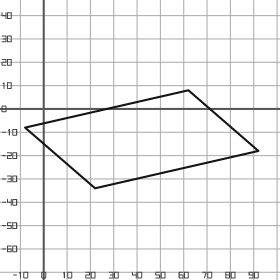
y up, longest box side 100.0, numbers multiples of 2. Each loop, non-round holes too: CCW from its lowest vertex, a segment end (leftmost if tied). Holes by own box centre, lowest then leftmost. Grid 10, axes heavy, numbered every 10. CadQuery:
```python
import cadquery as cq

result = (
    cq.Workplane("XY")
    .moveTo(22.0, -34.0)
    .lineTo(92.0, -18.0)
    .lineTo(62.0, 8.0)
    .lineTo(-8.0, -8.0)
    .close()
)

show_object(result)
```